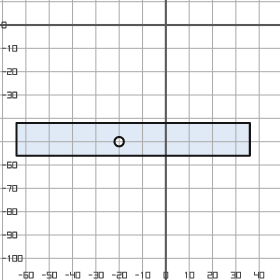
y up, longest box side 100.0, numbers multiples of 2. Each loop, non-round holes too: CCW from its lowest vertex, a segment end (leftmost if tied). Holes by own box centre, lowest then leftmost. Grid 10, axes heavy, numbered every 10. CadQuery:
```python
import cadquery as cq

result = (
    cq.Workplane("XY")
    .moveTo(-64.0, -56.0)
    .lineTo(36.0, -56.0)
    .lineTo(36.0, -42.0)
    .lineTo(-64.0, -42.0)
    .close()
    .moveTo(-20.0, -50.0)
    .circle(2.0)
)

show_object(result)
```